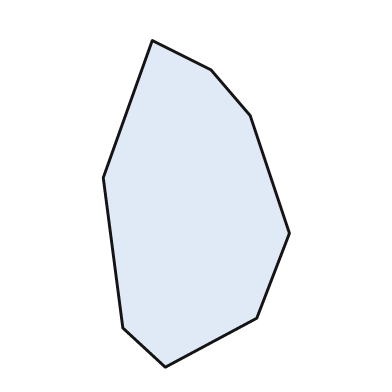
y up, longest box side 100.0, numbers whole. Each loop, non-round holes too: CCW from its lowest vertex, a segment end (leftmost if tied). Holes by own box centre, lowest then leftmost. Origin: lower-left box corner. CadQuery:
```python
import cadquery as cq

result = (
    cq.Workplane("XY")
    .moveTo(19.0, 0.0)
    .lineTo(47.0, 15.0)
    .lineTo(57.0, 41.0)
    .lineTo(45.0, 77.0)
    .lineTo(33.0, 91.0)
    .lineTo(15.0, 100.0)
    .lineTo(0.0, 58.0)
    .lineTo(6.0, 12.0)
    .close()
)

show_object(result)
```